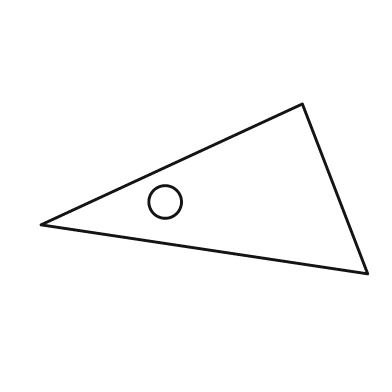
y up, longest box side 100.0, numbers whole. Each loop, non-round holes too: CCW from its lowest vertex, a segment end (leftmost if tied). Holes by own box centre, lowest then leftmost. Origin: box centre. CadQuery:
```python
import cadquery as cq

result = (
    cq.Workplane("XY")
    .moveTo(50.0, -26.0)
    .lineTo(30.0, 26.0)
    .lineTo(-50.0, -11.0)
    .close()
    .moveTo(-12.0, -4.0)
    .circle(5.0)
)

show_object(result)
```